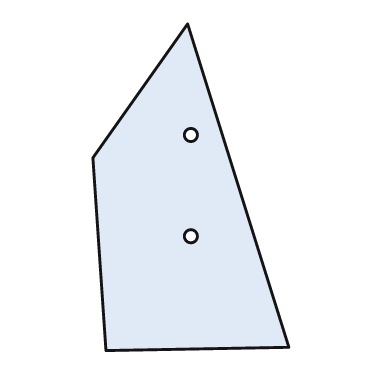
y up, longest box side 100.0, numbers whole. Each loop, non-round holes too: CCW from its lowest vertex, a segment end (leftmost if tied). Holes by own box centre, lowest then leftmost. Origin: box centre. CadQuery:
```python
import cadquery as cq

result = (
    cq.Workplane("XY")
    .moveTo(-26.0, -50.0)
    .lineTo(30.0, -49.0)
    .lineTo(-1.0, 50.0)
    .lineTo(-30.0, 9.0)
    .close()
    .moveTo(0.0, -15.0)
    .circle(2.0)
    .moveTo(0.0, 16.0)
    .circle(2.0)
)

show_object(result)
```